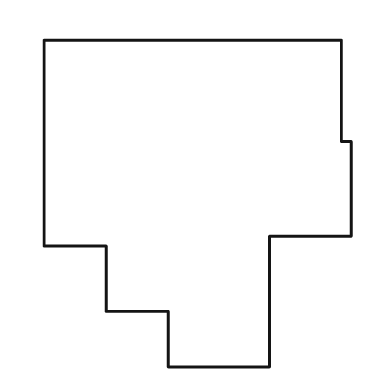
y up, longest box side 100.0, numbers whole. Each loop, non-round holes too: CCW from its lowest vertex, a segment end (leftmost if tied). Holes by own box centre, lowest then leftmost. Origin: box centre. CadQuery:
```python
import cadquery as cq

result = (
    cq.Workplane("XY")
    .moveTo(-9.0, -50.0)
    .lineTo(22.0, -50.0)
    .lineTo(22.0, -10.0)
    .lineTo(47.0, -10.0)
    .lineTo(47.0, 19.0)
    .lineTo(44.0, 19.0)
    .lineTo(44.0, 50.0)
    .lineTo(-47.0, 50.0)
    .lineTo(-47.0, -13.0)
    .lineTo(-28.0, -13.0)
    .lineTo(-28.0, -33.0)
    .lineTo(-9.0, -33.0)
    .close()
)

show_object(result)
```